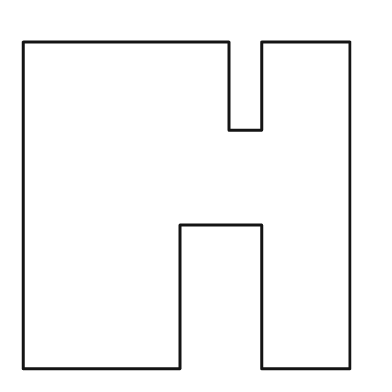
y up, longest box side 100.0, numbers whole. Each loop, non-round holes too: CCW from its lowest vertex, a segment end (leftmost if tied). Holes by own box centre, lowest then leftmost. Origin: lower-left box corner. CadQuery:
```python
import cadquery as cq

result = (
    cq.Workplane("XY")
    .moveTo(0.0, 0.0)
    .lineTo(48.0, 0.0)
    .lineTo(48.0, 44.0)
    .lineTo(73.0, 44.0)
    .lineTo(73.0, 0.0)
    .lineTo(100.0, 0.0)
    .lineTo(100.0, 100.0)
    .lineTo(73.0, 100.0)
    .lineTo(73.0, 73.0)
    .lineTo(63.0, 73.0)
    .lineTo(63.0, 100.0)
    .lineTo(0.0, 100.0)
    .close()
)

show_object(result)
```